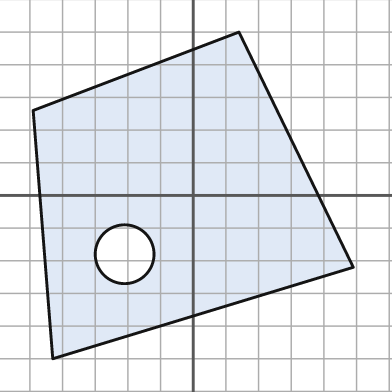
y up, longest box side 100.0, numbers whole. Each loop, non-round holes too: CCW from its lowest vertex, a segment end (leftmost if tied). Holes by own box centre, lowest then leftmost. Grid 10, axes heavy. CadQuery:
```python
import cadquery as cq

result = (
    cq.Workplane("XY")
    .moveTo(-43.0, -50.0)
    .lineTo(49.0, -22.0)
    .lineTo(14.0, 50.0)
    .lineTo(-49.0, 26.0)
    .close()
    .moveTo(-21.0, -18.0)
    .circle(9.0)
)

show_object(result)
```